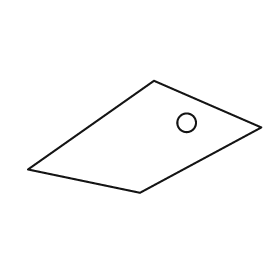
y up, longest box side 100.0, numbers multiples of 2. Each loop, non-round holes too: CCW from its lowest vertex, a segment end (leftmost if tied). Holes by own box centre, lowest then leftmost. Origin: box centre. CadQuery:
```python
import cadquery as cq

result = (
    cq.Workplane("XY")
    .moveTo(-2.0, -24.0)
    .lineTo(50.0, 4.0)
    .lineTo(4.0, 24.0)
    .lineTo(-50.0, -14.0)
    .close()
    .moveTo(18.0, 6.0)
    .circle(4.0)
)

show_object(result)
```